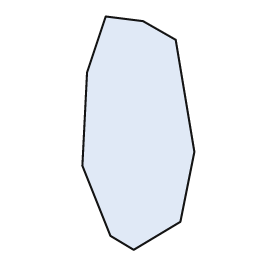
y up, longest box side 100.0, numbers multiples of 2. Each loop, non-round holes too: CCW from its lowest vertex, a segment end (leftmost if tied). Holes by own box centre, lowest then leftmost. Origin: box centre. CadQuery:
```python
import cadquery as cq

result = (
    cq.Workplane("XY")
    .moveTo(-2.0, -50.0)
    .lineTo(18.0, -38.0)
    .lineTo(24.0, -8.0)
    .lineTo(16.0, 40.0)
    .lineTo(2.0, 48.0)
    .lineTo(-14.0, 50.0)
    .lineTo(-22.0, 26.0)
    .lineTo(-24.0, -14.0)
    .lineTo(-12.0, -44.0)
    .close()
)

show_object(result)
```